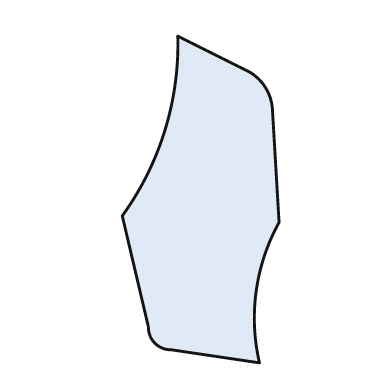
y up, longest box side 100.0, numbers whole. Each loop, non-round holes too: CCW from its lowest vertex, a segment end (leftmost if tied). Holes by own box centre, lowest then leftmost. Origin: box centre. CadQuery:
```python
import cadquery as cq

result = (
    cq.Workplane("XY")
    .moveTo(18.0, -50.0)
    .threePointArc((17.0, -28.0), (24.0, -7.0))
    .lineTo(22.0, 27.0)
    .threePointArc((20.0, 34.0), (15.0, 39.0))
    .lineTo(-7.0, 50.0)
    .threePointArc((-11.0, 21.0), (-24.0, -5.0))
    .lineTo(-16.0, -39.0)
    .threePointArc((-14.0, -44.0), (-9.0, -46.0))
    .close()
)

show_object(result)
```